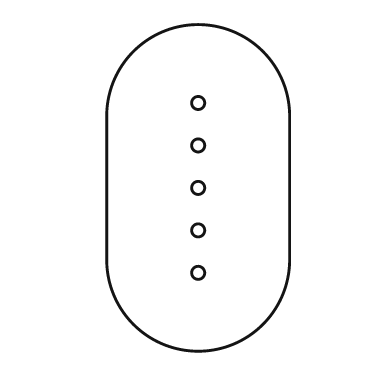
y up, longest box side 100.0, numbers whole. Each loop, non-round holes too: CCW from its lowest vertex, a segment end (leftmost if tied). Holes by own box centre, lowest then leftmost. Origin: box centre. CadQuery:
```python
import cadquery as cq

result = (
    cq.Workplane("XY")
    .moveTo(-28.0, -22.0)
    .threePointArc((0.0, -50.0), (28.0, -22.0))
    .lineTo(28.0, 22.0)
    .threePointArc((0.0, 50.0), (-28.0, 22.0))
    .close()
    .moveTo(0.0, -26.0)
    .circle(2.0)
    .moveTo(0.0, -13.0)
    .circle(2.0)
    .moveTo(0.0, 0.0)
    .circle(2.0)
    .moveTo(0.0, 13.0)
    .circle(2.0)
    .moveTo(0.0, 26.0)
    .circle(2.0)
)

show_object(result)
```